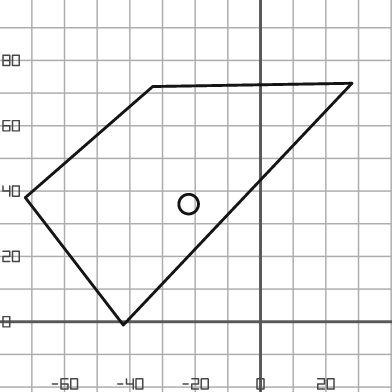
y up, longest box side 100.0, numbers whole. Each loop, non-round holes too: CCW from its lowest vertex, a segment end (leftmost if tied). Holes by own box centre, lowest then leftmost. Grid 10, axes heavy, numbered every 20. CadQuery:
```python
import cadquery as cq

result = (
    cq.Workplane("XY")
    .moveTo(-42.0, -1.0)
    .lineTo(28.0, 73.0)
    .lineTo(-33.0, 72.0)
    .lineTo(-72.0, 38.0)
    .close()
    .moveTo(-22.0, 36.0)
    .circle(3.0)
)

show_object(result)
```